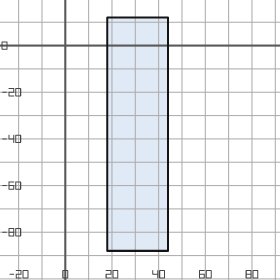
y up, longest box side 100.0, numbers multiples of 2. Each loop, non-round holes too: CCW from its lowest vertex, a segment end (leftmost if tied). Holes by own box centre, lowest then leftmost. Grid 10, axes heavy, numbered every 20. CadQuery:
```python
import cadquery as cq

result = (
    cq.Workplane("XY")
    .moveTo(18.0, -88.0)
    .lineTo(44.0, -88.0)
    .lineTo(44.0, 12.0)
    .lineTo(18.0, 12.0)
    .close()
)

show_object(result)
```